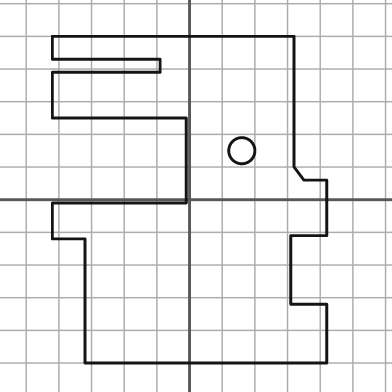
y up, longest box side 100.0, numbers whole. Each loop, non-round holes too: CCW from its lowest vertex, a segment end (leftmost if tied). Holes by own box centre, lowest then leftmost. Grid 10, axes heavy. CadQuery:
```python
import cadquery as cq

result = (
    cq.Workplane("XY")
    .moveTo(-32.0, -50.0)
    .lineTo(42.0, -50.0)
    .lineTo(42.0, -32.0)
    .lineTo(31.0, -32.0)
    .lineTo(31.0, -11.0)
    .lineTo(42.0, -11.0)
    .lineTo(42.0, 6.0)
    .lineTo(35.0, 6.0)
    .lineTo(32.0, 10.0)
    .lineTo(32.0, 50.0)
    .lineTo(-42.0, 50.0)
    .lineTo(-42.0, 43.0)
    .lineTo(-9.0, 43.0)
    .lineTo(-9.0, 39.0)
    .lineTo(-42.0, 39.0)
    .lineTo(-42.0, 25.0)
    .lineTo(-1.0, 25.0)
    .lineTo(-1.0, -1.0)
    .lineTo(-42.0, -1.0)
    .lineTo(-42.0, -12.0)
    .lineTo(-32.0, -12.0)
    .close()
    .moveTo(16.0, 15.0)
    .circle(4.0)
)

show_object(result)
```